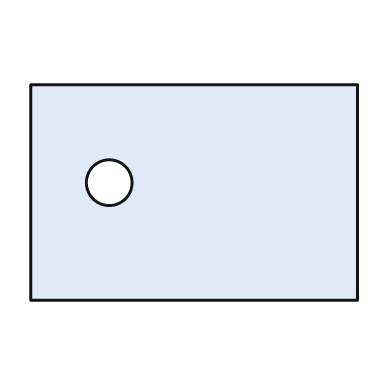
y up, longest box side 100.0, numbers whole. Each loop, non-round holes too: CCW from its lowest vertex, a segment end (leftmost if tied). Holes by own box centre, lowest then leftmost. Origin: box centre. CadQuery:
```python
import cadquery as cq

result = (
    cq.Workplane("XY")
    .moveTo(-50.0, -33.0)
    .lineTo(50.0, -33.0)
    .lineTo(50.0, 33.0)
    .lineTo(-50.0, 33.0)
    .close()
    .moveTo(-26.0, 3.0)
    .circle(7.0)
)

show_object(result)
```